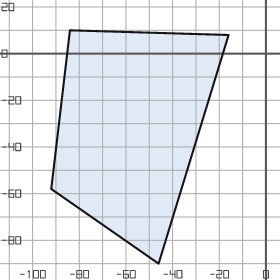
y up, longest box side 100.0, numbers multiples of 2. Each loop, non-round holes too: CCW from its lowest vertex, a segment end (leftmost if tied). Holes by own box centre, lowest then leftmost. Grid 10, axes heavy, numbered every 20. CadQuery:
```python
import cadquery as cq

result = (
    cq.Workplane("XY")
    .moveTo(-46.0, -90.0)
    .lineTo(-16.0, 8.0)
    .lineTo(-84.0, 10.0)
    .lineTo(-92.0, -58.0)
    .close()
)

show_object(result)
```